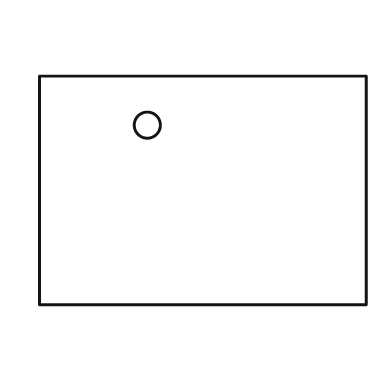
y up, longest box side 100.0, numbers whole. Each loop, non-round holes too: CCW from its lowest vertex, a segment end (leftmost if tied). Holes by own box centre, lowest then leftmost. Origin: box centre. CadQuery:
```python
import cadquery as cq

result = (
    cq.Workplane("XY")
    .moveTo(-50.0, -35.0)
    .lineTo(50.0, -35.0)
    .lineTo(50.0, 35.0)
    .lineTo(-50.0, 35.0)
    .close()
    .moveTo(-17.0, 20.0)
    .circle(4.0)
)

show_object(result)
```